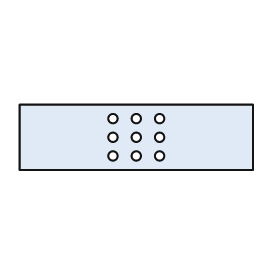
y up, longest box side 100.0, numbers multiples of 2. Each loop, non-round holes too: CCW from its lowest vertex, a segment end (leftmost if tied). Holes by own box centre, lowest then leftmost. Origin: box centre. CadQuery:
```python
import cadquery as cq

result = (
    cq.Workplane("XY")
    .moveTo(-50.0, -14.0)
    .lineTo(50.0, -14.0)
    .lineTo(50.0, 14.0)
    .lineTo(-50.0, 14.0)
    .close()
    .moveTo(-10.0, -8.0)
    .circle(2.0)
    .moveTo(0.0, -8.0)
    .circle(2.0)
    .moveTo(10.0, -8.0)
    .circle(2.0)
    .moveTo(-10.0, 0.0)
    .circle(2.0)
    .moveTo(0.0, 0.0)
    .circle(2.0)
    .moveTo(10.0, 0.0)
    .circle(2.0)
    .moveTo(-10.0, 8.0)
    .circle(2.0)
    .moveTo(0.0, 8.0)
    .circle(2.0)
    .moveTo(10.0, 8.0)
    .circle(2.0)
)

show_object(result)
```